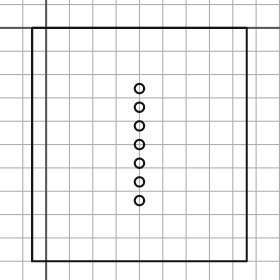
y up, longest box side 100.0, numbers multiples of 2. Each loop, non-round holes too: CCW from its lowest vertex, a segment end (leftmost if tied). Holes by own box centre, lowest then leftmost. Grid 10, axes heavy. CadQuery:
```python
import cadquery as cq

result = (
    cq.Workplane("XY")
    .moveTo(-6.0, -100.0)
    .lineTo(86.0, -100.0)
    .lineTo(86.0, 0.0)
    .lineTo(-6.0, 0.0)
    .close()
    .moveTo(40.0, -74.0)
    .circle(2.0)
    .moveTo(40.0, -66.0)
    .circle(2.0)
    .moveTo(40.0, -58.0)
    .circle(2.0)
    .moveTo(40.0, -50.0)
    .circle(2.0)
    .moveTo(40.0, -42.0)
    .circle(2.0)
    .moveTo(40.0, -34.0)
    .circle(2.0)
    .moveTo(40.0, -26.0)
    .circle(2.0)
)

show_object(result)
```